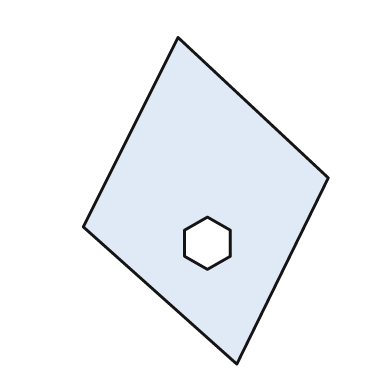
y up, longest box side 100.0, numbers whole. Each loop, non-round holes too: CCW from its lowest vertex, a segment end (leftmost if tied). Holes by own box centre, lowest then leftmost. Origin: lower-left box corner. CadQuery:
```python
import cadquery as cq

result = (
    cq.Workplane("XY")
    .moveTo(47.0, 0.0)
    .lineTo(75.0, 57.0)
    .lineTo(29.0, 100.0)
    .lineTo(0.0, 42.0)
    .close()
    .moveTo(38.0, 29.0)
    .lineTo(45.0, 33.0)
    .lineTo(45.0, 41.0)
    .lineTo(38.0, 45.0)
    .lineTo(31.0, 41.0)
    .lineTo(31.0, 33.0)
    .close()
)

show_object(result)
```